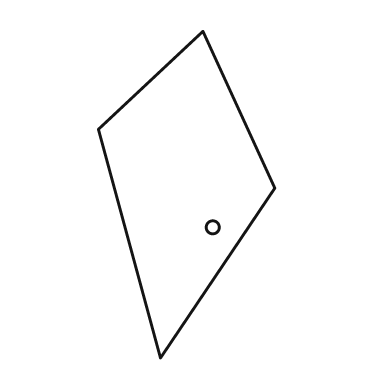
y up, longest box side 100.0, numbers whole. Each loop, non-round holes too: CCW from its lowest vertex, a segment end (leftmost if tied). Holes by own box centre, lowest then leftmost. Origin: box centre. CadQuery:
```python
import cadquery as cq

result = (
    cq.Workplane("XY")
    .moveTo(-8.0, -50.0)
    .lineTo(27.0, 2.0)
    .lineTo(5.0, 50.0)
    .lineTo(-27.0, 20.0)
    .close()
    .moveTo(8.0, -10.0)
    .circle(2.0)
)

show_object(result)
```